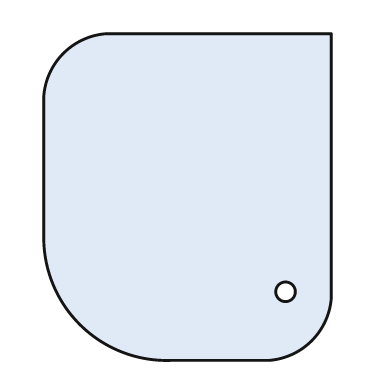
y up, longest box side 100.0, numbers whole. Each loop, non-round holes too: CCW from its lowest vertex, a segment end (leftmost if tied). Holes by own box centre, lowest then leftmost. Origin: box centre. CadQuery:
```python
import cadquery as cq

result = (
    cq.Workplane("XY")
    .moveTo(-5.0, -50.0)
    .lineTo(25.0, -50.0)
    .threePointArc((38.0, -44.0), (44.0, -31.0))
    .lineTo(44.0, 50.0)
    .lineTo(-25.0, 50.0)
    .threePointArc((-38.0, 44.0), (-44.0, 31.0))
    .lineTo(-44.0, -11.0)
    .threePointArc((-33.0, -39.0), (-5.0, -50.0))
    .close()
    .moveTo(30.0, -29.0)
    .circle(3.0)
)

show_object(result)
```